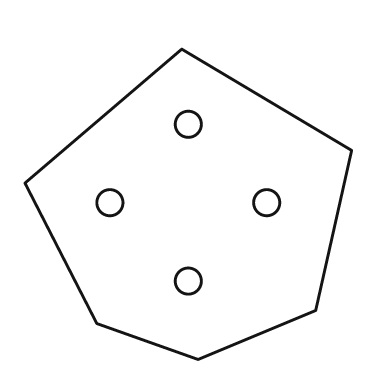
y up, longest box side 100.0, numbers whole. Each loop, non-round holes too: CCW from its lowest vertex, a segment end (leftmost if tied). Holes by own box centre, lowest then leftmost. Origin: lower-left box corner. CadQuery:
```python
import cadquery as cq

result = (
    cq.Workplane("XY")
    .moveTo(53.0, 0.0)
    .lineTo(89.0, 15.0)
    .lineTo(100.0, 64.0)
    .lineTo(48.0, 95.0)
    .lineTo(0.0, 54.0)
    .lineTo(22.0, 11.0)
    .close()
    .moveTo(50.0, 24.0)
    .circle(4.0)
    .moveTo(26.0, 48.0)
    .circle(4.0)
    .moveTo(74.0, 48.0)
    .circle(4.0)
    .moveTo(50.0, 72.0)
    .circle(4.0)
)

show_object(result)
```